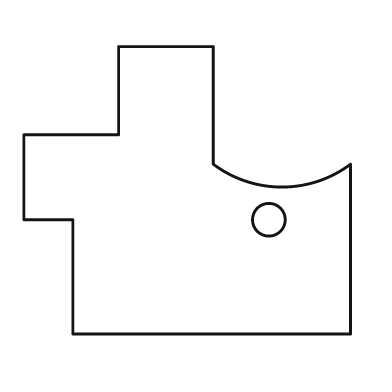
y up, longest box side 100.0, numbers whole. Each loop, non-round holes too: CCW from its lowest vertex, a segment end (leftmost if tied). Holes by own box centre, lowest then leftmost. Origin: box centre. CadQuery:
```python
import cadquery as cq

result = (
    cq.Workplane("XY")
    .moveTo(-35.0, -44.0)
    .lineTo(50.0, -44.0)
    .lineTo(50.0, 8.0)
    .threePointArc((29.0, 1.0), (8.0, 8.0))
    .lineTo(8.0, 44.0)
    .lineTo(-21.0, 44.0)
    .lineTo(-21.0, 17.0)
    .lineTo(-50.0, 17.0)
    .lineTo(-50.0, -9.0)
    .lineTo(-35.0, -9.0)
    .close()
    .moveTo(25.0, -9.0)
    .circle(5.0)
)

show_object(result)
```